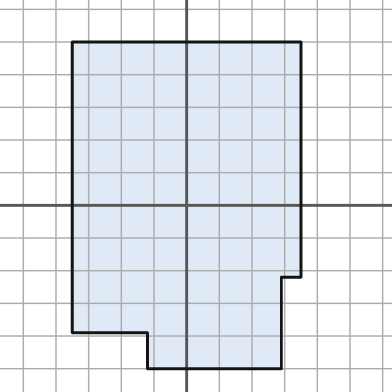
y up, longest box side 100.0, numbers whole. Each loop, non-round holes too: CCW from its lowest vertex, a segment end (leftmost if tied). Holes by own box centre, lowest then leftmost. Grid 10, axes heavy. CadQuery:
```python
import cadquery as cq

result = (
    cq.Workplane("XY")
    .moveTo(-12.0, -50.0)
    .lineTo(29.0, -50.0)
    .lineTo(29.0, -22.0)
    .lineTo(35.0, -22.0)
    .lineTo(35.0, 50.0)
    .lineTo(-35.0, 50.0)
    .lineTo(-35.0, -39.0)
    .lineTo(-12.0, -39.0)
    .close()
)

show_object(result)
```